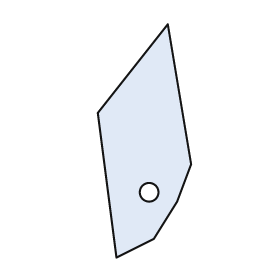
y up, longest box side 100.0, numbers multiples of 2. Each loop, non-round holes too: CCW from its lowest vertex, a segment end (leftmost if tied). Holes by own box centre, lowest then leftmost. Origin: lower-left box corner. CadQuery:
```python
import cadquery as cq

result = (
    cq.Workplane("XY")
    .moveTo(8.0, 0.0)
    .lineTo(24.0, 8.0)
    .lineTo(34.0, 24.0)
    .lineTo(40.0, 40.0)
    .lineTo(30.0, 100.0)
    .lineTo(0.0, 62.0)
    .close()
    .moveTo(22.0, 28.0)
    .circle(4.0)
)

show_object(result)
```